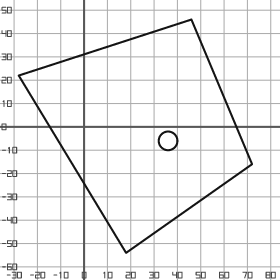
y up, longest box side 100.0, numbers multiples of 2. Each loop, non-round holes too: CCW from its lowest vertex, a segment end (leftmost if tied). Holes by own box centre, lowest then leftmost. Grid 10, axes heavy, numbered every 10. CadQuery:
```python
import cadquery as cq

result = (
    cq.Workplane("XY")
    .moveTo(18.0, -54.0)
    .lineTo(72.0, -16.0)
    .lineTo(46.0, 46.0)
    .lineTo(-28.0, 22.0)
    .close()
    .moveTo(36.0, -6.0)
    .circle(4.0)
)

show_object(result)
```